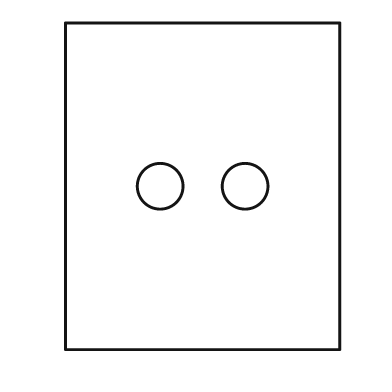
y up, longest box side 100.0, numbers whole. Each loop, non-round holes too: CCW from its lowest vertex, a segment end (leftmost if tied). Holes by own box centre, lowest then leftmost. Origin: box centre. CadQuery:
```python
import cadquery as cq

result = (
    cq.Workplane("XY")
    .moveTo(-42.0, -50.0)
    .lineTo(42.0, -50.0)
    .lineTo(42.0, 50.0)
    .lineTo(-42.0, 50.0)
    .close()
    .moveTo(-13.0, 0.0)
    .circle(7.0)
    .moveTo(13.0, 0.0)
    .circle(7.0)
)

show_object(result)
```